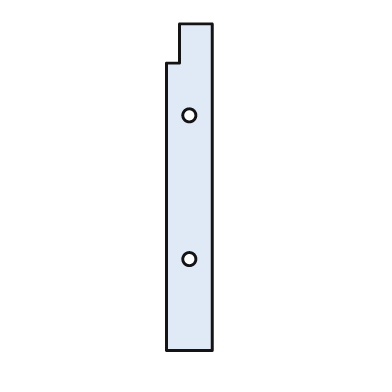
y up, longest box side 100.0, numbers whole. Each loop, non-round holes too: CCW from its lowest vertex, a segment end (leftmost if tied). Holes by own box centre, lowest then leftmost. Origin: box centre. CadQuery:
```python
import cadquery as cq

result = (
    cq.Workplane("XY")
    .moveTo(-7.0, -50.0)
    .lineTo(7.0, -50.0)
    .lineTo(7.0, 50.0)
    .lineTo(-3.0, 50.0)
    .lineTo(-3.0, 38.0)
    .lineTo(-7.0, 38.0)
    .close()
    .moveTo(0.0, -22.0)
    .circle(2.0)
    .moveTo(0.0, 22.0)
    .circle(2.0)
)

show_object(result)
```